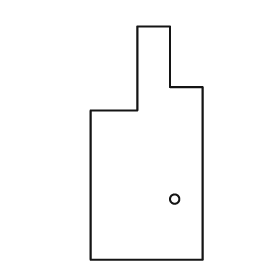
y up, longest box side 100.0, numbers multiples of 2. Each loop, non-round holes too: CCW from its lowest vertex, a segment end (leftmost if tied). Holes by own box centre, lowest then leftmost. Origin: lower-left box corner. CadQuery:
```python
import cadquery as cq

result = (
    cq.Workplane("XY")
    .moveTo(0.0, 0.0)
    .lineTo(48.0, 0.0)
    .lineTo(48.0, 74.0)
    .lineTo(34.0, 74.0)
    .lineTo(34.0, 100.0)
    .lineTo(20.0, 100.0)
    .lineTo(20.0, 64.0)
    .lineTo(0.0, 64.0)
    .close()
    .moveTo(36.0, 26.0)
    .circle(2.0)
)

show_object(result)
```